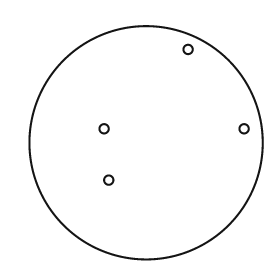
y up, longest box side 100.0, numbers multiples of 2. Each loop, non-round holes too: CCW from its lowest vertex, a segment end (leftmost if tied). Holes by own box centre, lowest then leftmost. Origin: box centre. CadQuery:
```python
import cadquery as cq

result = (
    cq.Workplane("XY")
    .moveTo(0.0, 0.0)
    .circle(50.0)
    .moveTo(-16.0, -16.0)
    .circle(2.0)
    .moveTo(-18.0, 6.0)
    .circle(2.0)
    .moveTo(42.0, 6.0)
    .circle(2.0)
    .moveTo(18.0, 40.0)
    .circle(2.0)
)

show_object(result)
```